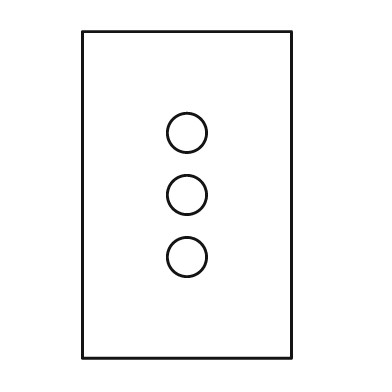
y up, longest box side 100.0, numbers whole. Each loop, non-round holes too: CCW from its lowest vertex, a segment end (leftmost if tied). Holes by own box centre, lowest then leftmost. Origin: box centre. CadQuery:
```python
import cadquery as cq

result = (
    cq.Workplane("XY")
    .moveTo(-32.0, -50.0)
    .lineTo(32.0, -50.0)
    .lineTo(32.0, 50.0)
    .lineTo(-32.0, 50.0)
    .close()
    .moveTo(0.0, -19.0)
    .circle(6.0)
    .moveTo(0.0, 0.0)
    .circle(6.0)
    .moveTo(0.0, 19.0)
    .circle(6.0)
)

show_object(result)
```